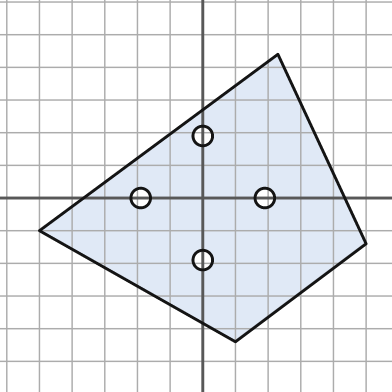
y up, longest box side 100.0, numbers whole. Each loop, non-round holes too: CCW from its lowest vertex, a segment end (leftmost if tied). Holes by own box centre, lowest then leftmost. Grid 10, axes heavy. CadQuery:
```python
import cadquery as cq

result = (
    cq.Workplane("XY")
    .moveTo(10.0, -44.0)
    .lineTo(50.0, -14.0)
    .lineTo(23.0, 44.0)
    .lineTo(-50.0, -10.0)
    .close()
    .moveTo(0.0, -19.0)
    .circle(3.0)
    .moveTo(-19.0, 0.0)
    .circle(3.0)
    .moveTo(19.0, 0.0)
    .circle(3.0)
    .moveTo(0.0, 19.0)
    .circle(3.0)
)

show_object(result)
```